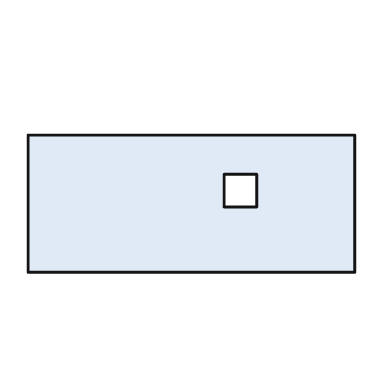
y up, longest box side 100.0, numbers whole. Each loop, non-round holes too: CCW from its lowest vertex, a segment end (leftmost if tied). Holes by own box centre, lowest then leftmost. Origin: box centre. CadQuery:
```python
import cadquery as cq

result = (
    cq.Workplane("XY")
    .moveTo(-50.0, -21.0)
    .lineTo(50.0, -21.0)
    .lineTo(50.0, 21.0)
    .lineTo(-50.0, 21.0)
    .close()
    .moveTo(10.0, -1.0)
    .lineTo(20.0, -1.0)
    .lineTo(20.0, 9.0)
    .lineTo(10.0, 9.0)
    .close()
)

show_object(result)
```